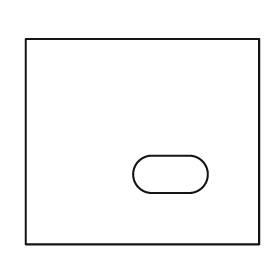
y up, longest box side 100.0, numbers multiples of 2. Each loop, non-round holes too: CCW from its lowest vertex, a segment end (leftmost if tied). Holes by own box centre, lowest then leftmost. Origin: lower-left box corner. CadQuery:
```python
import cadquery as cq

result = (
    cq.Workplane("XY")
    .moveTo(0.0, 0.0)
    .lineTo(100.0, 0.0)
    .lineTo(100.0, 88.0)
    .lineTo(0.0, 88.0)
    .close()
    .moveTo(54.0, 22.0)
    .lineTo(70.0, 22.0)
    .threePointArc((78.0, 30.0), (70.0, 38.0))
    .lineTo(54.0, 38.0)
    .threePointArc((46.0, 30.0), (54.0, 22.0))
    .close()
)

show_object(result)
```